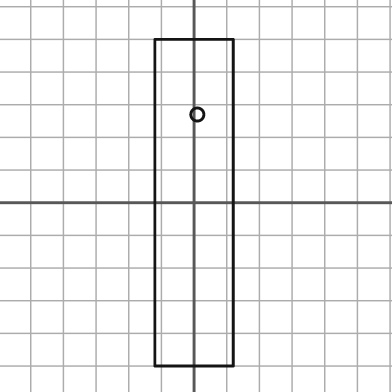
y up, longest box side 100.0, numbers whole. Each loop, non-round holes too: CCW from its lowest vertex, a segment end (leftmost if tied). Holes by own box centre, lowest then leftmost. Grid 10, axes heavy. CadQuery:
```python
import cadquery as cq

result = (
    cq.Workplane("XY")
    .moveTo(-12.0, -50.0)
    .lineTo(12.0, -50.0)
    .lineTo(12.0, 50.0)
    .lineTo(-12.0, 50.0)
    .close()
    .moveTo(1.0, 27.0)
    .circle(2.0)
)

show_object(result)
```